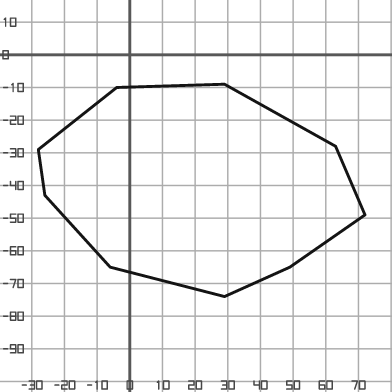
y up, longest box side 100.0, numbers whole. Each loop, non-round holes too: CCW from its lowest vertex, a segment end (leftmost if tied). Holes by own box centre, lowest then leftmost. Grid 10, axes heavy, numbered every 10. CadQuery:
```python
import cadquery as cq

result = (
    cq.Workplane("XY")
    .moveTo(29.0, -74.0)
    .lineTo(49.0, -65.0)
    .lineTo(72.0, -49.0)
    .lineTo(63.0, -28.0)
    .lineTo(29.0, -9.0)
    .lineTo(-4.0, -10.0)
    .lineTo(-28.0, -29.0)
    .lineTo(-26.0, -43.0)
    .lineTo(-6.0, -65.0)
    .close()
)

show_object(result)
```